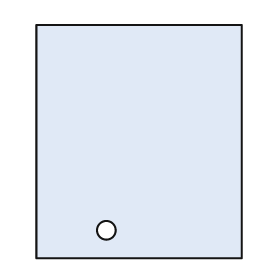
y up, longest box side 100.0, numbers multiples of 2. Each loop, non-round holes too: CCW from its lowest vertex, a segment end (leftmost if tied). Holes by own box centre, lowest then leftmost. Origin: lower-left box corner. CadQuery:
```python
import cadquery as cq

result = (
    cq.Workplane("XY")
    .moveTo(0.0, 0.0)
    .lineTo(88.0, 0.0)
    .lineTo(88.0, 100.0)
    .lineTo(0.0, 100.0)
    .close()
    .moveTo(30.0, 12.0)
    .circle(4.0)
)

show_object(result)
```